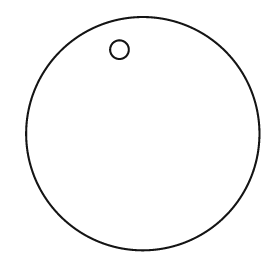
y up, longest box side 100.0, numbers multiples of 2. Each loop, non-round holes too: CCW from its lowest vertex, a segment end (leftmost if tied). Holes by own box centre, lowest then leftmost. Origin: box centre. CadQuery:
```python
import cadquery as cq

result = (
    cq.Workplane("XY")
    .moveTo(0.0, 0.0)
    .circle(50.0)
    .moveTo(-10.0, 36.0)
    .circle(4.0)
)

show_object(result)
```